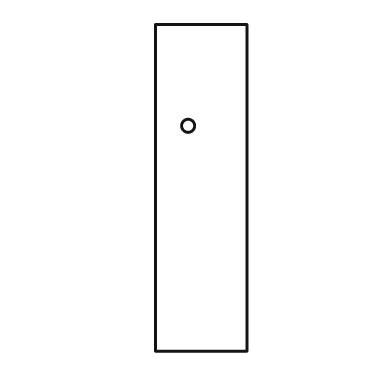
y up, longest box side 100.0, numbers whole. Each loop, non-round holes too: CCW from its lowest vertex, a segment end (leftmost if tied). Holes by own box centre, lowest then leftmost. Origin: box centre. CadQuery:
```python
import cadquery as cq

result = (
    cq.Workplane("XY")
    .moveTo(-14.0, -50.0)
    .lineTo(14.0, -50.0)
    .lineTo(14.0, 50.0)
    .lineTo(-14.0, 50.0)
    .close()
    .moveTo(-4.0, 19.0)
    .circle(2.0)
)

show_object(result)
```